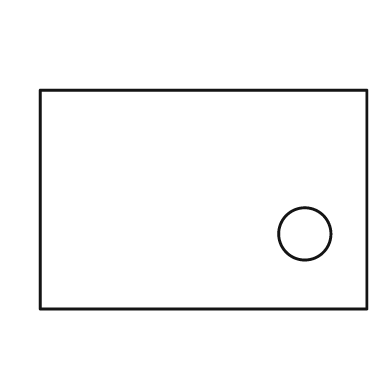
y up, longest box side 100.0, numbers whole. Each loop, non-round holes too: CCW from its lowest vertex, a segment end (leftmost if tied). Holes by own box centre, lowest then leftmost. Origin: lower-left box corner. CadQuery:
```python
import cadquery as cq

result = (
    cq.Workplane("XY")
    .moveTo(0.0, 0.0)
    .lineTo(100.0, 0.0)
    .lineTo(100.0, 67.0)
    .lineTo(0.0, 67.0)
    .close()
    .moveTo(81.0, 23.0)
    .circle(8.0)
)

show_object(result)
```